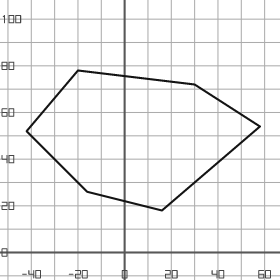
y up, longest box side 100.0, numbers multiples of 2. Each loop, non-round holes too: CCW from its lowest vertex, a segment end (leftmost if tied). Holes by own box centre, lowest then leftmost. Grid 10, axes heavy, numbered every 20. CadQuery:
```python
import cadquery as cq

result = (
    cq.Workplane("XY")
    .moveTo(16.0, 18.0)
    .lineTo(58.0, 54.0)
    .lineTo(30.0, 72.0)
    .lineTo(-20.0, 78.0)
    .lineTo(-42.0, 52.0)
    .lineTo(-16.0, 26.0)
    .close()
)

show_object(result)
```